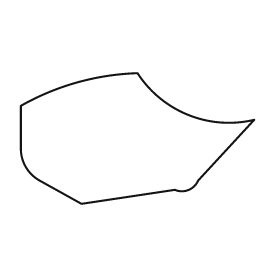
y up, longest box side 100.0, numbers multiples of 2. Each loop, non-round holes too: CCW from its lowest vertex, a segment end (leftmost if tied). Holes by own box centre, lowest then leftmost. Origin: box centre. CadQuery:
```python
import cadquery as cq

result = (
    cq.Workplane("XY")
    .moveTo(-24.0, -28.0)
    .lineTo(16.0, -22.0)
    .threePointArc((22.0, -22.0), (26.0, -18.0))
    .lineTo(50.0, 8.0)
    .threePointArc((22.0, 10.0), (0.0, 28.0))
    .threePointArc((-26.0, 24.0), (-50.0, 14.0))
    .lineTo(-50.0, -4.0)
    .threePointArc((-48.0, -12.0), (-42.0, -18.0))
    .close()
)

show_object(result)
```